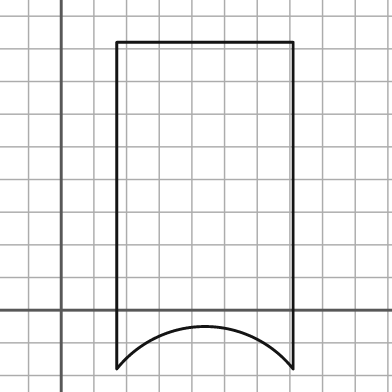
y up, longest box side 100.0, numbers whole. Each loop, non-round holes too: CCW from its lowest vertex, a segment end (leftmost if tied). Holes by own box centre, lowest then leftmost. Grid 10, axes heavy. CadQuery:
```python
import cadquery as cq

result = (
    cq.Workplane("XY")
    .moveTo(17.0, -18.0)
    .threePointArc((44.0, -5.0), (71.0, -18.0))
    .lineTo(71.0, 82.0)
    .lineTo(17.0, 82.0)
    .close()
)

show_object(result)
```